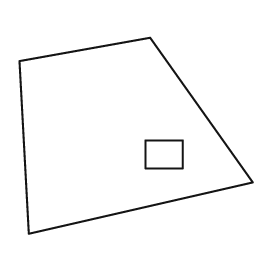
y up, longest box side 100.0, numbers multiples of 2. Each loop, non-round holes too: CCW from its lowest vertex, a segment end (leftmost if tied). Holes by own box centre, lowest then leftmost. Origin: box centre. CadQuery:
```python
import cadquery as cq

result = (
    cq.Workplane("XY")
    .moveTo(-46.0, -42.0)
    .lineTo(50.0, -20.0)
    .lineTo(6.0, 42.0)
    .lineTo(-50.0, 32.0)
    .close()
    .moveTo(4.0, -14.0)
    .lineTo(20.0, -14.0)
    .lineTo(20.0, -2.0)
    .lineTo(4.0, -2.0)
    .close()
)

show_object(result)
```